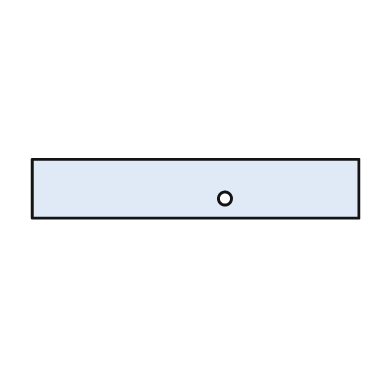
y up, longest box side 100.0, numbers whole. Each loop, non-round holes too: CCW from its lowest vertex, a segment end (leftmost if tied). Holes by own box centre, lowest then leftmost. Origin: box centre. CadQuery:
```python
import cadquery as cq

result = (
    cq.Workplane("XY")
    .moveTo(-50.0, -9.0)
    .lineTo(50.0, -9.0)
    .lineTo(50.0, 9.0)
    .lineTo(-50.0, 9.0)
    .close()
    .moveTo(9.0, -3.0)
    .circle(2.0)
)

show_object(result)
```